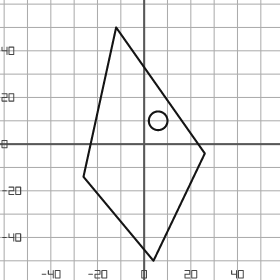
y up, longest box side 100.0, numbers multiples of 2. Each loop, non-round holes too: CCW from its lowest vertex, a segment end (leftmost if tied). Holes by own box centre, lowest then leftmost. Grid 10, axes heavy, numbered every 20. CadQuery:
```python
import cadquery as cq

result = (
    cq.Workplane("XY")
    .moveTo(4.0, -50.0)
    .lineTo(26.0, -4.0)
    .lineTo(-12.0, 50.0)
    .lineTo(-26.0, -14.0)
    .close()
    .moveTo(6.0, 10.0)
    .circle(4.0)
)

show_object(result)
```